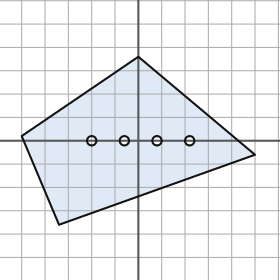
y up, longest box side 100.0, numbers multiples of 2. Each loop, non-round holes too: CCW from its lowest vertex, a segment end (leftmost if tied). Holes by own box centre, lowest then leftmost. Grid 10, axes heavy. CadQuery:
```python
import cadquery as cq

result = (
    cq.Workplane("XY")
    .moveTo(-34.0, -36.0)
    .lineTo(50.0, -6.0)
    .lineTo(0.0, 36.0)
    .lineTo(-50.0, 2.0)
    .close()
    .moveTo(-20.0, 0.0)
    .circle(2.0)
    .moveTo(-6.0, 0.0)
    .circle(2.0)
    .moveTo(8.0, 0.0)
    .circle(2.0)
    .moveTo(22.0, 0.0)
    .circle(2.0)
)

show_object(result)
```